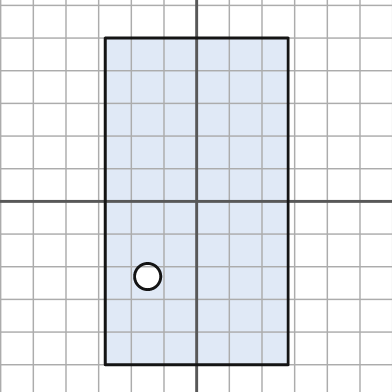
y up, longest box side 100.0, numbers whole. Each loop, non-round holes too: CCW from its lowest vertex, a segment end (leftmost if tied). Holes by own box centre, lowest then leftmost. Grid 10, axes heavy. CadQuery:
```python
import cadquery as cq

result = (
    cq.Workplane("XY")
    .moveTo(-28.0, -50.0)
    .lineTo(28.0, -50.0)
    .lineTo(28.0, 50.0)
    .lineTo(-28.0, 50.0)
    .close()
    .moveTo(-15.0, -23.0)
    .circle(4.0)
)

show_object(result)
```